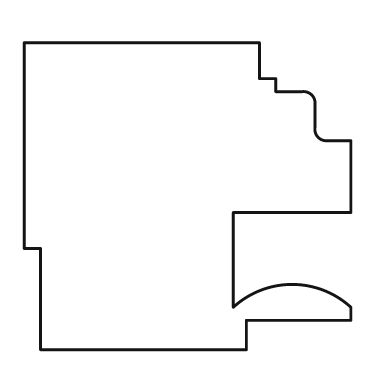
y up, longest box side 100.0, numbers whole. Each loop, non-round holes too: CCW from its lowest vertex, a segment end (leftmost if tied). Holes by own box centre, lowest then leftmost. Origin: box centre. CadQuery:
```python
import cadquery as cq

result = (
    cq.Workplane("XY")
    .moveTo(-45.0, -47.0)
    .lineTo(18.0, -47.0)
    .lineTo(18.0, -38.0)
    .lineTo(50.0, -38.0)
    .lineTo(50.0, -34.0)
    .threePointArc((32.0, -27.0), (14.0, -34.0))
    .lineTo(14.0, -5.0)
    .lineTo(50.0, -5.0)
    .lineTo(50.0, 17.0)
    .lineTo(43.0, 17.0)
    .threePointArc((40.0, 18.0), (39.0, 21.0))
    .lineTo(39.0, 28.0)
    .threePointArc((38.0, 31.0), (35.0, 32.0))
    .lineTo(27.0, 32.0)
    .lineTo(27.0, 36.0)
    .lineTo(22.0, 36.0)
    .lineTo(22.0, 47.0)
    .lineTo(-50.0, 47.0)
    .lineTo(-50.0, -16.0)
    .lineTo(-45.0, -16.0)
    .close()
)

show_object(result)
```